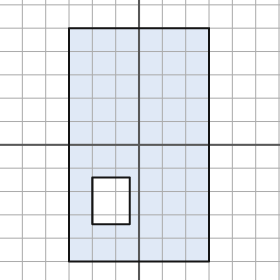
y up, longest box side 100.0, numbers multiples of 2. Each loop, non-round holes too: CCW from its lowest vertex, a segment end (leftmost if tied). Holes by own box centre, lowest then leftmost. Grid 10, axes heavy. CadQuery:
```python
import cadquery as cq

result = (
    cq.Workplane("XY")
    .moveTo(-30.0, -50.0)
    .lineTo(30.0, -50.0)
    .lineTo(30.0, 50.0)
    .lineTo(-30.0, 50.0)
    .close()
    .moveTo(-20.0, -34.0)
    .lineTo(-4.0, -34.0)
    .lineTo(-4.0, -14.0)
    .lineTo(-20.0, -14.0)
    .close()
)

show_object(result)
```